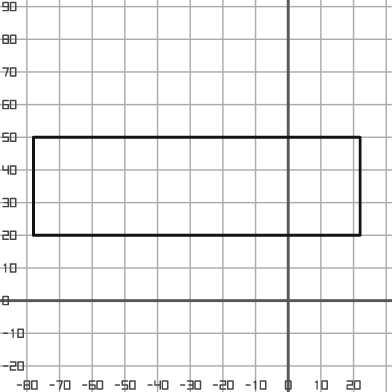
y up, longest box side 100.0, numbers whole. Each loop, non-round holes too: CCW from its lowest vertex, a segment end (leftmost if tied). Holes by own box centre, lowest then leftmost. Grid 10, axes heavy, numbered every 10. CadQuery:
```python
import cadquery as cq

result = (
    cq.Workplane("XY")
    .moveTo(-78.0, 20.0)
    .lineTo(22.0, 20.0)
    .lineTo(22.0, 50.0)
    .lineTo(-78.0, 50.0)
    .close()
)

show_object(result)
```